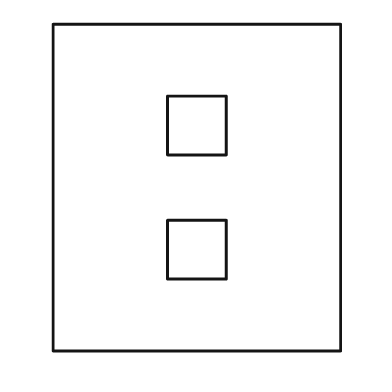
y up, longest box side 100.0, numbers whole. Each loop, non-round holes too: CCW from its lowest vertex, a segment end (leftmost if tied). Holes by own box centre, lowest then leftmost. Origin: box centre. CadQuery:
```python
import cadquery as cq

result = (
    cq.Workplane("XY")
    .moveTo(-44.0, -50.0)
    .lineTo(44.0, -50.0)
    .lineTo(44.0, 50.0)
    .lineTo(-44.0, 50.0)
    .close()
    .moveTo(-9.0, -28.0)
    .lineTo(9.0, -28.0)
    .lineTo(9.0, -10.0)
    .lineTo(-9.0, -10.0)
    .close()
    .moveTo(-9.0, 10.0)
    .lineTo(9.0, 10.0)
    .lineTo(9.0, 28.0)
    .lineTo(-9.0, 28.0)
    .close()
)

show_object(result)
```